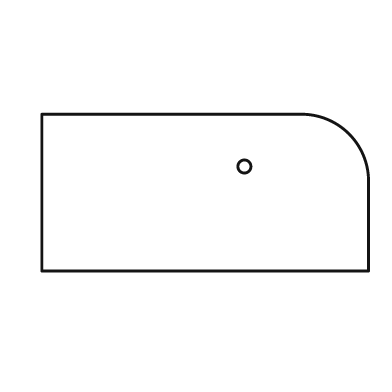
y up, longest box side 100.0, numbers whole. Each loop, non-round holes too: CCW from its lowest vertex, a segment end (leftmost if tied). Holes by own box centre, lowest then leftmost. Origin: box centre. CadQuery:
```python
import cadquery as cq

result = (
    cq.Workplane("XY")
    .moveTo(-50.0, -24.0)
    .lineTo(50.0, -24.0)
    .lineTo(50.0, 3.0)
    .threePointArc((44.0, 18.0), (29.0, 24.0))
    .lineTo(-50.0, 24.0)
    .close()
    .moveTo(12.0, 8.0)
    .circle(2.0)
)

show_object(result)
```